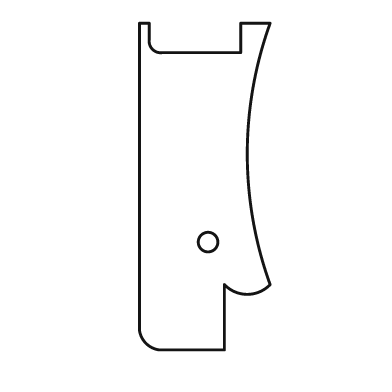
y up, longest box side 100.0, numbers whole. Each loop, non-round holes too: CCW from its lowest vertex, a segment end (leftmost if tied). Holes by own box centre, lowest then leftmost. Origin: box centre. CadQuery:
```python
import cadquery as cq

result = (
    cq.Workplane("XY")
    .moveTo(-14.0, -50.0)
    .lineTo(6.0, -50.0)
    .lineTo(6.0, -30.0)
    .threePointArc((13.0, -33.0), (20.0, -30.0))
    .threePointArc((13.0, 10.0), (20.0, 50.0))
    .lineTo(11.0, 50.0)
    .lineTo(11.0, 41.0)
    .lineTo(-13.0, 41.0)
    .threePointArc((-16.0, 42.0), (-17.0, 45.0))
    .lineTo(-17.0, 50.0)
    .lineTo(-20.0, 50.0)
    .lineTo(-20.0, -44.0)
    .threePointArc((-18.0, -48.0), (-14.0, -50.0))
    .close()
    .moveTo(1.0, -17.0)
    .circle(3.0)
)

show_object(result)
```